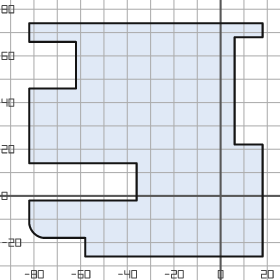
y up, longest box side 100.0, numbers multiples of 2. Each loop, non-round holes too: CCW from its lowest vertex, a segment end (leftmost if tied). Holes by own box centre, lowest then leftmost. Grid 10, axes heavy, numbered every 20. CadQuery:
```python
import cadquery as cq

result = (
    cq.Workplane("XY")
    .moveTo(-58.0, -26.0)
    .lineTo(18.0, -26.0)
    .lineTo(18.0, 22.0)
    .lineTo(6.0, 22.0)
    .lineTo(6.0, 68.0)
    .lineTo(18.0, 68.0)
    .lineTo(18.0, 74.0)
    .lineTo(-82.0, 74.0)
    .lineTo(-82.0, 66.0)
    .lineTo(-62.0, 66.0)
    .lineTo(-62.0, 46.0)
    .lineTo(-82.0, 46.0)
    .lineTo(-82.0, 14.0)
    .lineTo(-36.0, 14.0)
    .lineTo(-36.0, -2.0)
    .lineTo(-82.0, -2.0)
    .lineTo(-82.0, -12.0)
    .threePointArc((-80.0, -16.0), (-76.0, -18.0))
    .lineTo(-58.0, -18.0)
    .close()
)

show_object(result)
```